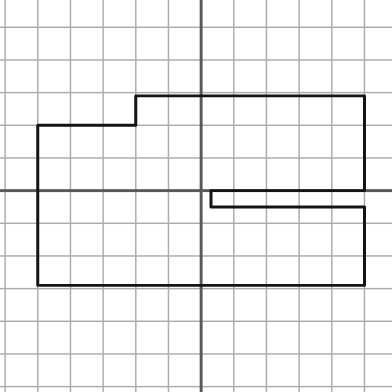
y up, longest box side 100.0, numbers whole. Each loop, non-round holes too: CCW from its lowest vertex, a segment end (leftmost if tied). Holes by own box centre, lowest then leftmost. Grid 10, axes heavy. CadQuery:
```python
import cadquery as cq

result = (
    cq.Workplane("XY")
    .moveTo(-50.0, -29.0)
    .lineTo(50.0, -29.0)
    .lineTo(50.0, -5.0)
    .lineTo(3.0, -5.0)
    .lineTo(3.0, 0.0)
    .lineTo(50.0, 0.0)
    .lineTo(50.0, 29.0)
    .lineTo(-20.0, 29.0)
    .lineTo(-20.0, 20.0)
    .lineTo(-50.0, 20.0)
    .close()
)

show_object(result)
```